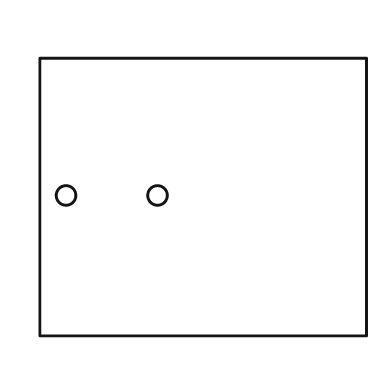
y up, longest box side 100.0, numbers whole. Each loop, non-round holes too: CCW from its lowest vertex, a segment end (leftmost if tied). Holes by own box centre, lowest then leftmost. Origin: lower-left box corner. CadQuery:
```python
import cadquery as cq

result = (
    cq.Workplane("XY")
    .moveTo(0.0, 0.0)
    .lineTo(100.0, 0.0)
    .lineTo(100.0, 85.0)
    .lineTo(0.0, 85.0)
    .close()
    .moveTo(8.0, 43.0)
    .circle(3.0)
    .moveTo(36.0, 43.0)
    .circle(3.0)
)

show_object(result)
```